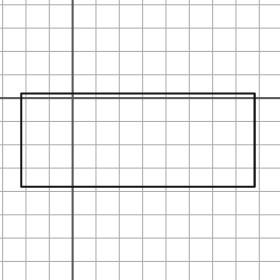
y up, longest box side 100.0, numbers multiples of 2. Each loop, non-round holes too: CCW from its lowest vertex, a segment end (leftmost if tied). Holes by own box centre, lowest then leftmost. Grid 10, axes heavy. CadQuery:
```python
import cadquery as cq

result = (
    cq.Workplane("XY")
    .moveTo(-22.0, -38.0)
    .lineTo(78.0, -38.0)
    .lineTo(78.0, 2.0)
    .lineTo(-22.0, 2.0)
    .close()
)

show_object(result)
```